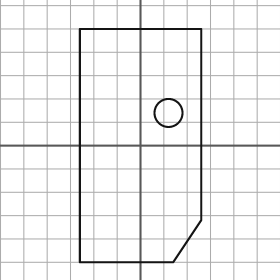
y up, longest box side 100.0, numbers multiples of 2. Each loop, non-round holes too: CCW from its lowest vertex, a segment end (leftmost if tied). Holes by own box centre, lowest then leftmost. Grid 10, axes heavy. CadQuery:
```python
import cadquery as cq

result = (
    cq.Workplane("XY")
    .moveTo(-26.0, -50.0)
    .lineTo(14.0, -50.0)
    .lineTo(26.0, -32.0)
    .lineTo(26.0, 50.0)
    .lineTo(-26.0, 50.0)
    .close()
    .moveTo(12.0, 14.0)
    .circle(6.0)
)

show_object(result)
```